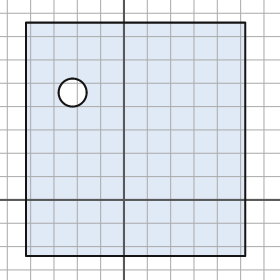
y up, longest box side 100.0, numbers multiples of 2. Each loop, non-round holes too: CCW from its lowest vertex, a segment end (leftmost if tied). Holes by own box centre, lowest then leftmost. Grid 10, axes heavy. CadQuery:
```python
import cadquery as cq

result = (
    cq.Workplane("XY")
    .moveTo(-42.0, -24.0)
    .lineTo(52.0, -24.0)
    .lineTo(52.0, 76.0)
    .lineTo(-42.0, 76.0)
    .close()
    .moveTo(-22.0, 46.0)
    .circle(6.0)
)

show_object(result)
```